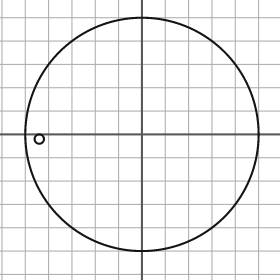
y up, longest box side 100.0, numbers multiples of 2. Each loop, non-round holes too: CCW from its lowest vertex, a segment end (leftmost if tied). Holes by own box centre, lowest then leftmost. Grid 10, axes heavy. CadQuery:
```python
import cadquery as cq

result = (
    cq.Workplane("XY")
    .moveTo(0.0, 0.0)
    .circle(50.0)
    .moveTo(-44.0, -2.0)
    .circle(2.0)
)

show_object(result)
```